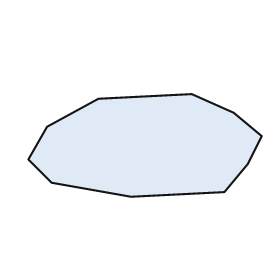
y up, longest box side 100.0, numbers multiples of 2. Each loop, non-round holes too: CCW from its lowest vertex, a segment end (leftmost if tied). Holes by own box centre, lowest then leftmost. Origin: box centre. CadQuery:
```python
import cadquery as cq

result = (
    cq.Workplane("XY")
    .moveTo(-6.0, -22.0)
    .lineTo(34.0, -20.0)
    .lineTo(44.0, -8.0)
    .lineTo(50.0, 4.0)
    .lineTo(38.0, 14.0)
    .lineTo(20.0, 22.0)
    .lineTo(-20.0, 20.0)
    .lineTo(-42.0, 8.0)
    .lineTo(-50.0, -6.0)
    .lineTo(-40.0, -16.0)
    .close()
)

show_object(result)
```